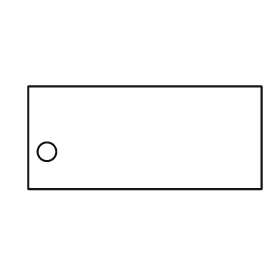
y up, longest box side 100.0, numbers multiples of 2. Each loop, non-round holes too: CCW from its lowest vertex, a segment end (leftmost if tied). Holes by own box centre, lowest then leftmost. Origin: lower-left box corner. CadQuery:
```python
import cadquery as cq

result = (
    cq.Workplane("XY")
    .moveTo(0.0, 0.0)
    .lineTo(100.0, 0.0)
    .lineTo(100.0, 44.0)
    .lineTo(0.0, 44.0)
    .close()
    .moveTo(8.0, 16.0)
    .circle(4.0)
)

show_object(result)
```